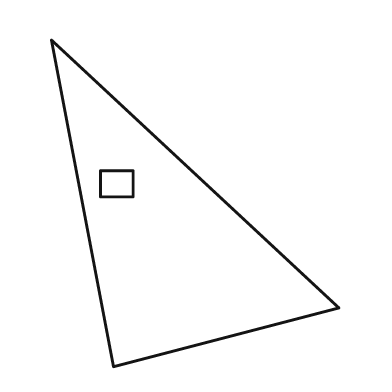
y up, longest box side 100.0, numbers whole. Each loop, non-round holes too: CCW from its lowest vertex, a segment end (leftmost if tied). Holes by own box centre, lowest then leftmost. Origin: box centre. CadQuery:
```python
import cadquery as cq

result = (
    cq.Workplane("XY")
    .moveTo(-25.0, -50.0)
    .lineTo(44.0, -32.0)
    .lineTo(-44.0, 50.0)
    .close()
    .moveTo(-29.0, 2.0)
    .lineTo(-19.0, 2.0)
    .lineTo(-19.0, 10.0)
    .lineTo(-29.0, 10.0)
    .close()
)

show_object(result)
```